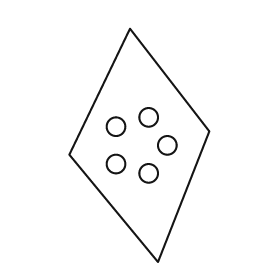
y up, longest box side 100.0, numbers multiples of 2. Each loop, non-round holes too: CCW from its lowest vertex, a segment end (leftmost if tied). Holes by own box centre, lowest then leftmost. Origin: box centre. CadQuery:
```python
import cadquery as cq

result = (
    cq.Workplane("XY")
    .moveTo(8.0, -50.0)
    .lineTo(30.0, 6.0)
    .lineTo(-4.0, 50.0)
    .lineTo(-30.0, -4.0)
    .close()
    .moveTo(4.0, -12.0)
    .circle(4.0)
    .moveTo(-10.0, -8.0)
    .circle(4.0)
    .moveTo(12.0, 0.0)
    .circle(4.0)
    .moveTo(-10.0, 8.0)
    .circle(4.0)
    .moveTo(4.0, 12.0)
    .circle(4.0)
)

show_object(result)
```